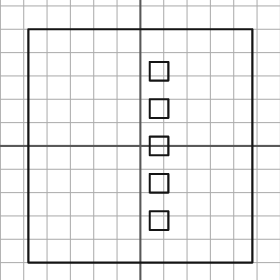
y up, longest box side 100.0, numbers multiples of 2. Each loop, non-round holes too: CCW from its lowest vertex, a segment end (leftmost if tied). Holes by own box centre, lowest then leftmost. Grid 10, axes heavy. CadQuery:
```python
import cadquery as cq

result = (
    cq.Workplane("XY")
    .moveTo(-48.0, -50.0)
    .lineTo(48.0, -50.0)
    .lineTo(48.0, 50.0)
    .lineTo(-48.0, 50.0)
    .close()
    .moveTo(4.0, -36.0)
    .lineTo(12.0, -36.0)
    .lineTo(12.0, -28.0)
    .lineTo(4.0, -28.0)
    .close()
    .moveTo(4.0, -20.0)
    .lineTo(12.0, -20.0)
    .lineTo(12.0, -12.0)
    .lineTo(4.0, -12.0)
    .close()
    .moveTo(4.0, -4.0)
    .lineTo(12.0, -4.0)
    .lineTo(12.0, 4.0)
    .lineTo(4.0, 4.0)
    .close()
    .moveTo(4.0, 12.0)
    .lineTo(12.0, 12.0)
    .lineTo(12.0, 20.0)
    .lineTo(4.0, 20.0)
    .close()
    .moveTo(4.0, 28.0)
    .lineTo(12.0, 28.0)
    .lineTo(12.0, 36.0)
    .lineTo(4.0, 36.0)
    .close()
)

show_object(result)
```